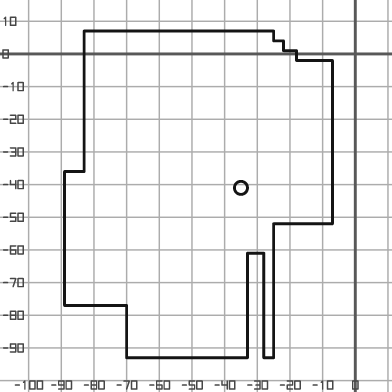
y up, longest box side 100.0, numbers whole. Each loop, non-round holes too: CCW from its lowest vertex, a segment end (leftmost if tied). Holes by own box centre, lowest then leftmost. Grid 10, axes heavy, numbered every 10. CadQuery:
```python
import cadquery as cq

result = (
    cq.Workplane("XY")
    .moveTo(-70.0, -93.0)
    .lineTo(-33.0, -93.0)
    .lineTo(-33.0, -61.0)
    .lineTo(-28.0, -61.0)
    .lineTo(-28.0, -93.0)
    .lineTo(-25.0, -93.0)
    .lineTo(-25.0, -52.0)
    .lineTo(-7.0, -52.0)
    .lineTo(-7.0, -2.0)
    .lineTo(-18.0, -2.0)
    .lineTo(-18.0, 1.0)
    .lineTo(-22.0, 1.0)
    .lineTo(-22.0, 4.0)
    .lineTo(-25.0, 4.0)
    .lineTo(-25.0, 7.0)
    .lineTo(-83.0, 7.0)
    .lineTo(-83.0, -36.0)
    .lineTo(-89.0, -36.0)
    .lineTo(-89.0, -77.0)
    .lineTo(-70.0, -77.0)
    .close()
    .moveTo(-35.0, -41.0)
    .circle(2.0)
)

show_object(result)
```